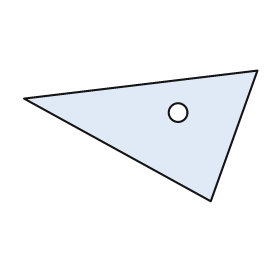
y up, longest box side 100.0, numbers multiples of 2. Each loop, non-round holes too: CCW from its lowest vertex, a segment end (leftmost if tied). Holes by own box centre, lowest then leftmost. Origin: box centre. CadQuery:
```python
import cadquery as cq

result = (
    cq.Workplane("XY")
    .moveTo(30.0, -28.0)
    .lineTo(50.0, 28.0)
    .lineTo(-50.0, 16.0)
    .close()
    .moveTo(16.0, 10.0)
    .circle(4.0)
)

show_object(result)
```